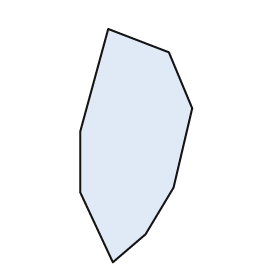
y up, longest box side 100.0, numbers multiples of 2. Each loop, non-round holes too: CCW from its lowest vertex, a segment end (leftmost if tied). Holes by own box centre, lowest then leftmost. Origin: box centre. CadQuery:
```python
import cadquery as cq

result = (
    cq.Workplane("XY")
    .moveTo(-10.0, -50.0)
    .lineTo(4.0, -38.0)
    .lineTo(16.0, -18.0)
    .lineTo(24.0, 16.0)
    .lineTo(14.0, 40.0)
    .lineTo(-12.0, 50.0)
    .lineTo(-24.0, 6.0)
    .lineTo(-24.0, -20.0)
    .close()
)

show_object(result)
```